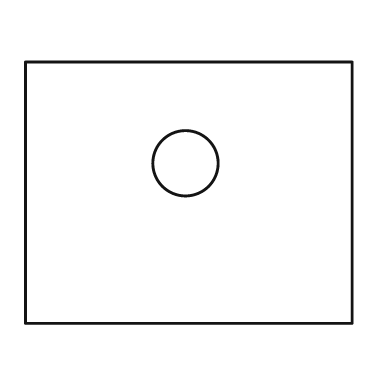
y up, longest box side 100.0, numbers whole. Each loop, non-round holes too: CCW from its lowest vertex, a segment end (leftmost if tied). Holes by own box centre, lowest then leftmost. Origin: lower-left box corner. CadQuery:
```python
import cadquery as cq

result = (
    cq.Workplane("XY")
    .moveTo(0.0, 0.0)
    .lineTo(100.0, 0.0)
    .lineTo(100.0, 80.0)
    .lineTo(0.0, 80.0)
    .close()
    .moveTo(49.0, 49.0)
    .circle(10.0)
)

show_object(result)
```